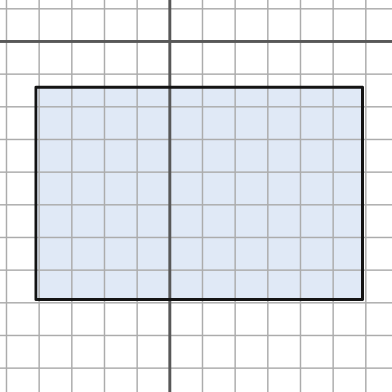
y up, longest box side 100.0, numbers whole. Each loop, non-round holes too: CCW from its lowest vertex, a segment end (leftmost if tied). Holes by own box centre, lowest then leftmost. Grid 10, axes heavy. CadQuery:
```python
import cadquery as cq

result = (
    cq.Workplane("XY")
    .moveTo(-41.0, -79.0)
    .lineTo(59.0, -79.0)
    .lineTo(59.0, -14.0)
    .lineTo(-41.0, -14.0)
    .close()
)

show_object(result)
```